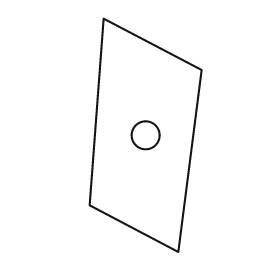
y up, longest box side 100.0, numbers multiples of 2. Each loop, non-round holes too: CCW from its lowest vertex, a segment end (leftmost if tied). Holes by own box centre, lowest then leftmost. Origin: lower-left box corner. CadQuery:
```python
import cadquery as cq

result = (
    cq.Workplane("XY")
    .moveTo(38.0, 0.0)
    .lineTo(48.0, 78.0)
    .lineTo(6.0, 100.0)
    .lineTo(0.0, 20.0)
    .close()
    .moveTo(24.0, 50.0)
    .circle(6.0)
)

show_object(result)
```